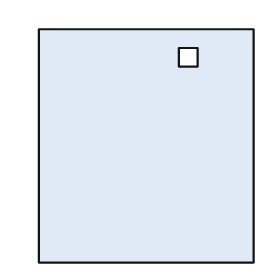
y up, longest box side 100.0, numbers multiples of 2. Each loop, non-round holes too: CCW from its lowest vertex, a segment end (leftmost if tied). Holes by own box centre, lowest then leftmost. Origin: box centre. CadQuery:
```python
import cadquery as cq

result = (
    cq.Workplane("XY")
    .moveTo(-46.0, -50.0)
    .lineTo(46.0, -50.0)
    .lineTo(46.0, 50.0)
    .lineTo(-46.0, 50.0)
    .close()
    .moveTo(14.0, 34.0)
    .lineTo(22.0, 34.0)
    .lineTo(22.0, 42.0)
    .lineTo(14.0, 42.0)
    .close()
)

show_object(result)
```